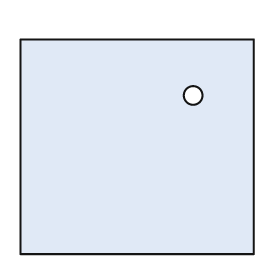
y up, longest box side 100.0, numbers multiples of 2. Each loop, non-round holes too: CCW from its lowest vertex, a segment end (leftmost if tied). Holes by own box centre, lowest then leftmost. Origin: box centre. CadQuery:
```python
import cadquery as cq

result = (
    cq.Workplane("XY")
    .moveTo(-50.0, -46.0)
    .lineTo(50.0, -46.0)
    .lineTo(50.0, 46.0)
    .lineTo(-50.0, 46.0)
    .close()
    .moveTo(24.0, 22.0)
    .circle(4.0)
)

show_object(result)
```